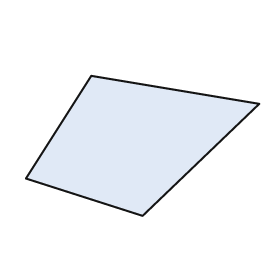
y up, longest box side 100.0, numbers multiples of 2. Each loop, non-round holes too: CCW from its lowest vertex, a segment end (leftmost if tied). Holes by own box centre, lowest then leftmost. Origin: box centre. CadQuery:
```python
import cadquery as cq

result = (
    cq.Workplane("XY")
    .moveTo(0.0, -30.0)
    .lineTo(50.0, 18.0)
    .lineTo(-22.0, 30.0)
    .lineTo(-50.0, -14.0)
    .close()
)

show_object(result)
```